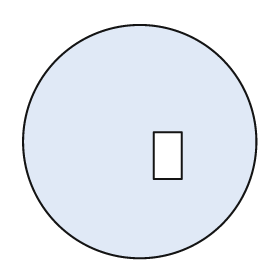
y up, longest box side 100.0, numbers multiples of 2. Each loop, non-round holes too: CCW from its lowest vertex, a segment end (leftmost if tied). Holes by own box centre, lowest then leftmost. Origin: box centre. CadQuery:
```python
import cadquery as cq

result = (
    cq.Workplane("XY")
    .moveTo(0.0, 0.0)
    .circle(50.0)
    .moveTo(6.0, -16.0)
    .lineTo(18.0, -16.0)
    .lineTo(18.0, 4.0)
    .lineTo(6.0, 4.0)
    .close()
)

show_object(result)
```